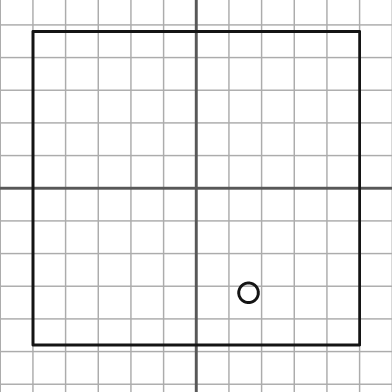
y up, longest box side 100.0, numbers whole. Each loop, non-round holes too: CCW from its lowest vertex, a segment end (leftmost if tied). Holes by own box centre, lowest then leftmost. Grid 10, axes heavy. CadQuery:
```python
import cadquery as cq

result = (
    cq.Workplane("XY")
    .moveTo(-50.0, -48.0)
    .lineTo(50.0, -48.0)
    .lineTo(50.0, 48.0)
    .lineTo(-50.0, 48.0)
    .close()
    .moveTo(16.0, -32.0)
    .circle(3.0)
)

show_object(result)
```